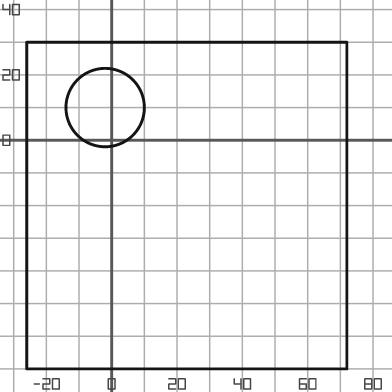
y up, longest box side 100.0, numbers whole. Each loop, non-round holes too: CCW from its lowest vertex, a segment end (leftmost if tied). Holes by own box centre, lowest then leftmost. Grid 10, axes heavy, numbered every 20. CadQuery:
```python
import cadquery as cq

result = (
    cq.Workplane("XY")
    .moveTo(-26.0, -70.0)
    .lineTo(72.0, -70.0)
    .lineTo(72.0, 30.0)
    .lineTo(-26.0, 30.0)
    .close()
    .moveTo(-2.0, 10.0)
    .circle(12.0)
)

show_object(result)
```